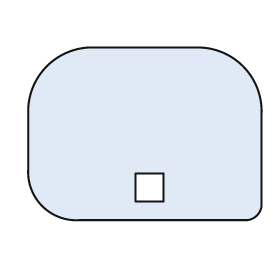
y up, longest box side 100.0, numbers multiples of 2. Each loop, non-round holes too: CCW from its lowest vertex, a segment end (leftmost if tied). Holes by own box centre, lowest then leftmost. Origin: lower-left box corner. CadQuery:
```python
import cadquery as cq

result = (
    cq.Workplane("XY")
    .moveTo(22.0, 0.0)
    .lineTo(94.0, 0.0)
    .threePointArc((98.0, 2.0), (100.0, 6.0))
    .lineTo(100.0, 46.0)
    .threePointArc((92.0, 66.0), (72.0, 74.0))
    .lineTo(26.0, 74.0)
    .threePointArc((8.0, 66.0), (0.0, 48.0))
    .lineTo(0.0, 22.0)
    .threePointArc((6.0, 6.0), (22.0, 0.0))
    .close()
    .moveTo(46.0, 8.0)
    .lineTo(58.0, 8.0)
    .lineTo(58.0, 20.0)
    .lineTo(46.0, 20.0)
    .close()
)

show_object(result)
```